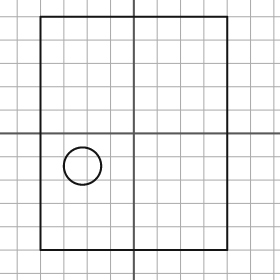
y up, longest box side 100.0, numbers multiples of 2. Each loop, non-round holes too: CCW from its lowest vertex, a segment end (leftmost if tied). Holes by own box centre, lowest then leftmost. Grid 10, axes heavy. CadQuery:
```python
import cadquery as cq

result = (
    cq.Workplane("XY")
    .moveTo(-40.0, -50.0)
    .lineTo(40.0, -50.0)
    .lineTo(40.0, 50.0)
    .lineTo(-40.0, 50.0)
    .close()
    .moveTo(-22.0, -14.0)
    .circle(8.0)
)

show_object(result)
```